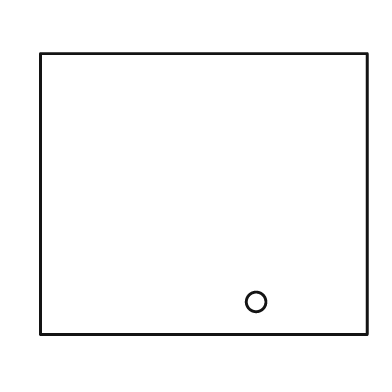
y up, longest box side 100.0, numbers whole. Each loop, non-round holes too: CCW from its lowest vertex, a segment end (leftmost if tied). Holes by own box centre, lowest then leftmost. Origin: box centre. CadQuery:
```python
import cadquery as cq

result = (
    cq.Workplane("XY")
    .moveTo(-50.0, -43.0)
    .lineTo(50.0, -43.0)
    .lineTo(50.0, 43.0)
    .lineTo(-50.0, 43.0)
    .close()
    .moveTo(16.0, -33.0)
    .circle(3.0)
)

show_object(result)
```